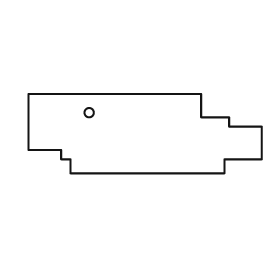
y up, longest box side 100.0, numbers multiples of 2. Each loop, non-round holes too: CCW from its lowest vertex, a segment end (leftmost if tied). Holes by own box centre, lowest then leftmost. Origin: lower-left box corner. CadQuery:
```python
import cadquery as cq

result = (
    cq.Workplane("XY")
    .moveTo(18.0, 0.0)
    .lineTo(84.0, 0.0)
    .lineTo(84.0, 6.0)
    .lineTo(100.0, 6.0)
    .lineTo(100.0, 20.0)
    .lineTo(86.0, 20.0)
    .lineTo(86.0, 24.0)
    .lineTo(74.0, 24.0)
    .lineTo(74.0, 34.0)
    .lineTo(0.0, 34.0)
    .lineTo(0.0, 10.0)
    .lineTo(14.0, 10.0)
    .lineTo(14.0, 6.0)
    .lineTo(18.0, 6.0)
    .close()
    .moveTo(26.0, 26.0)
    .circle(2.0)
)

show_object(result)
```